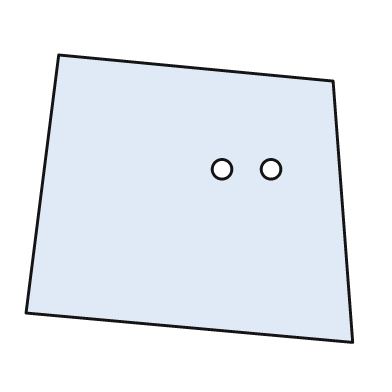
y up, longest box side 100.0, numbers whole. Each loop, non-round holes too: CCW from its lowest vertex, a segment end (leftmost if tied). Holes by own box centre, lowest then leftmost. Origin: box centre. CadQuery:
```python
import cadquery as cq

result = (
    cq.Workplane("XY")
    .moveTo(50.0, -44.0)
    .lineTo(44.0, 36.0)
    .lineTo(-40.0, 44.0)
    .lineTo(-50.0, -35.0)
    .close()
    .moveTo(10.0, 9.0)
    .circle(3.0)
    .moveTo(25.0, 9.0)
    .circle(3.0)
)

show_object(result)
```